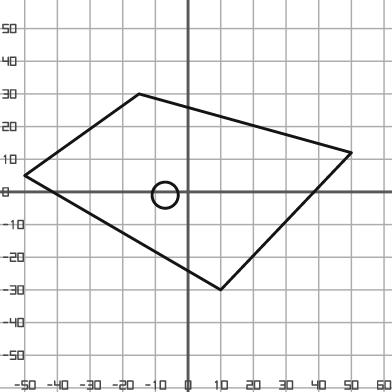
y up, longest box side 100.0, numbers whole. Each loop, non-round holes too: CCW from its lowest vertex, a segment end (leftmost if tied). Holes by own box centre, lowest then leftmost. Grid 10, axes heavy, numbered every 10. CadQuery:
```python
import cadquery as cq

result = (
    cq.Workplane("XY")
    .moveTo(10.0, -30.0)
    .lineTo(50.0, 12.0)
    .lineTo(-15.0, 30.0)
    .lineTo(-50.0, 5.0)
    .close()
    .moveTo(-7.0, -1.0)
    .circle(4.0)
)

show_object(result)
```